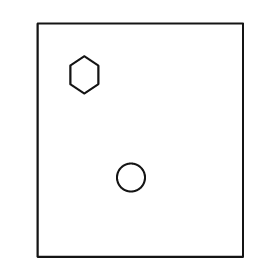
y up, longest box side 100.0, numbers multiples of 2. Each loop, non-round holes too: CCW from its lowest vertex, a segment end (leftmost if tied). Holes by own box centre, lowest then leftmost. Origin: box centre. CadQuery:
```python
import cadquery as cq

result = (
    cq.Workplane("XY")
    .moveTo(-44.0, -50.0)
    .lineTo(44.0, -50.0)
    .lineTo(44.0, 50.0)
    .lineTo(-44.0, 50.0)
    .close()
    .moveTo(-4.0, -16.0)
    .circle(6.0)
    .moveTo(-24.0, 20.0)
    .lineTo(-18.0, 24.0)
    .lineTo(-18.0, 32.0)
    .lineTo(-24.0, 36.0)
    .lineTo(-30.0, 32.0)
    .lineTo(-30.0, 24.0)
    .close()
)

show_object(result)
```